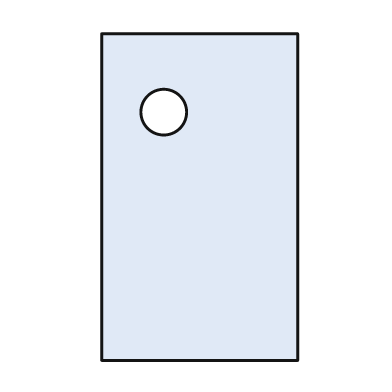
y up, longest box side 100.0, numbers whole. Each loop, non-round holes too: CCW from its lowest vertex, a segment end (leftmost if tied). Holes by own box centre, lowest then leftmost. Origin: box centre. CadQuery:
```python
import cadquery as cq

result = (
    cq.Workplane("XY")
    .moveTo(-30.0, -50.0)
    .lineTo(30.0, -50.0)
    .lineTo(30.0, 50.0)
    .lineTo(-30.0, 50.0)
    .close()
    .moveTo(-11.0, 26.0)
    .circle(7.0)
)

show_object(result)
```